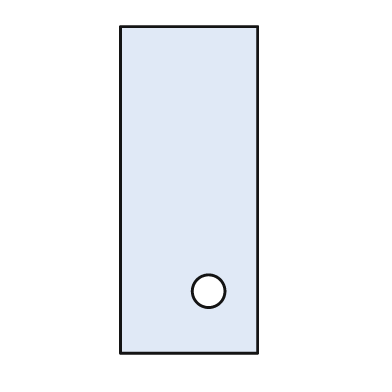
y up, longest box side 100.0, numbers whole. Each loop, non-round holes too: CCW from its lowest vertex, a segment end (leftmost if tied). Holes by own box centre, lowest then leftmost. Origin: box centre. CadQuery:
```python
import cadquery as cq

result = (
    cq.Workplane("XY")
    .moveTo(-21.0, -50.0)
    .lineTo(21.0, -50.0)
    .lineTo(21.0, 50.0)
    .lineTo(-21.0, 50.0)
    .close()
    .moveTo(6.0, -31.0)
    .circle(5.0)
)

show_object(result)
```